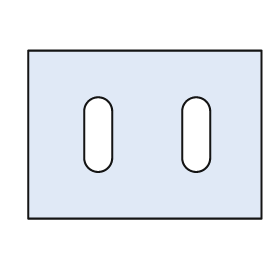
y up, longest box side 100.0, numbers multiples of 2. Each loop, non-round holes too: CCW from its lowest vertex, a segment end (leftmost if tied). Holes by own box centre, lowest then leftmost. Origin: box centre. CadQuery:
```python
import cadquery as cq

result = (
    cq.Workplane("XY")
    .moveTo(-50.0, -36.0)
    .lineTo(50.0, -36.0)
    .lineTo(50.0, 36.0)
    .lineTo(-50.0, 36.0)
    .close()
    .moveTo(-26.0, -10.0)
    .threePointArc((-20.0, -16.0), (-14.0, -10.0))
    .lineTo(-14.0, 10.0)
    .threePointArc((-20.0, 16.0), (-26.0, 10.0))
    .close()
    .moveTo(16.0, -10.0)
    .threePointArc((22.0, -16.0), (28.0, -10.0))
    .lineTo(28.0, 10.0)
    .threePointArc((22.0, 16.0), (16.0, 10.0))
    .close()
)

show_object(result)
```